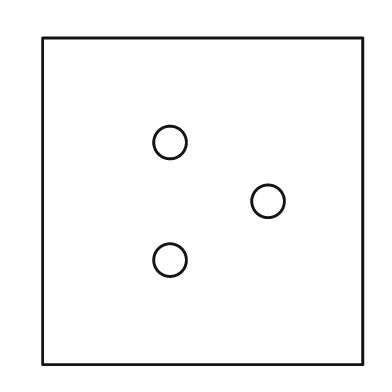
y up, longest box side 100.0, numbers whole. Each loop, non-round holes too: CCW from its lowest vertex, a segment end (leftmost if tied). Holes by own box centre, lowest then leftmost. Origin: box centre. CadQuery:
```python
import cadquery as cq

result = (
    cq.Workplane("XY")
    .moveTo(-49.0, -50.0)
    .lineTo(49.0, -50.0)
    .lineTo(49.0, 50.0)
    .lineTo(-49.0, 50.0)
    .close()
    .moveTo(-10.0, -18.0)
    .circle(5.0)
    .moveTo(20.0, 0.0)
    .circle(5.0)
    .moveTo(-10.0, 18.0)
    .circle(5.0)
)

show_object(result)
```